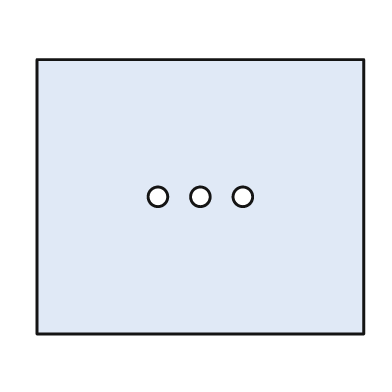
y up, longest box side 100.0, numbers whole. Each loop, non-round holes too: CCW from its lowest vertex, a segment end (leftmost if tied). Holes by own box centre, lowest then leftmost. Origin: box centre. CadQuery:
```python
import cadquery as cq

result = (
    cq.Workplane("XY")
    .moveTo(-50.0, -42.0)
    .lineTo(50.0, -42.0)
    .lineTo(50.0, 42.0)
    .lineTo(-50.0, 42.0)
    .close()
    .moveTo(-13.0, 0.0)
    .circle(3.0)
    .moveTo(0.0, 0.0)
    .circle(3.0)
    .moveTo(13.0, 0.0)
    .circle(3.0)
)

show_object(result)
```